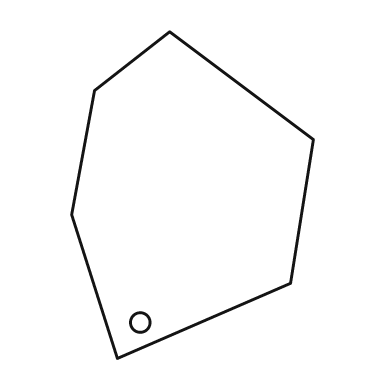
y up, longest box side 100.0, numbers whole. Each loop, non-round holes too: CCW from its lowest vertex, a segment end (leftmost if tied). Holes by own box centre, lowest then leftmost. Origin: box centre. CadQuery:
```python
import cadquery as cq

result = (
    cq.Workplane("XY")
    .moveTo(-23.0, -50.0)
    .lineTo(30.0, -27.0)
    .lineTo(37.0, 17.0)
    .lineTo(-7.0, 50.0)
    .lineTo(-30.0, 32.0)
    .lineTo(-37.0, -6.0)
    .close()
    .moveTo(-16.0, -39.0)
    .circle(3.0)
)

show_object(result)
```